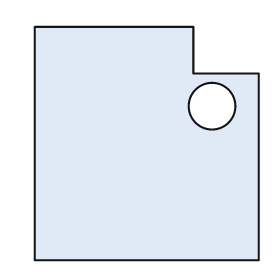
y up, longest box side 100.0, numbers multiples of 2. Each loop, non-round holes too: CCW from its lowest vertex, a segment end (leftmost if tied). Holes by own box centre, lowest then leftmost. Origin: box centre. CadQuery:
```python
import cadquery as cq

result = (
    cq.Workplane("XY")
    .moveTo(-48.0, -50.0)
    .lineTo(48.0, -50.0)
    .lineTo(48.0, 30.0)
    .lineTo(20.0, 30.0)
    .lineTo(20.0, 50.0)
    .lineTo(-48.0, 50.0)
    .close()
    .moveTo(28.0, 16.0)
    .circle(10.0)
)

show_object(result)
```